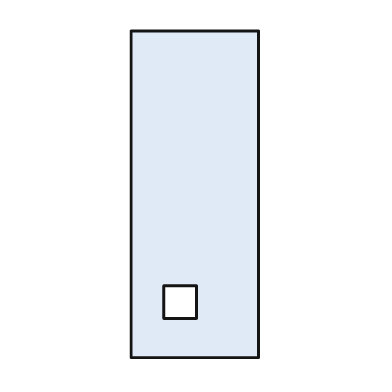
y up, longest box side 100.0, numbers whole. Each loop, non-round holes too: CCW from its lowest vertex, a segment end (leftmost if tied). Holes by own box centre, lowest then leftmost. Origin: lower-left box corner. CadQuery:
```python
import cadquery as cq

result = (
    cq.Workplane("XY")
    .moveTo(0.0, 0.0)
    .lineTo(39.0, 0.0)
    .lineTo(39.0, 100.0)
    .lineTo(0.0, 100.0)
    .close()
    .moveTo(10.0, 12.0)
    .lineTo(20.0, 12.0)
    .lineTo(20.0, 22.0)
    .lineTo(10.0, 22.0)
    .close()
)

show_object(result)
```